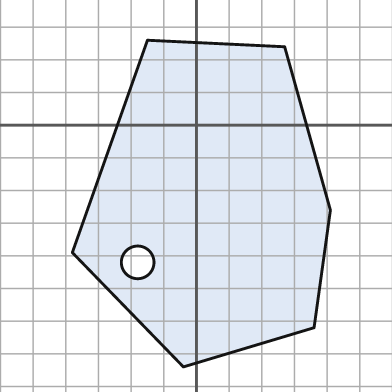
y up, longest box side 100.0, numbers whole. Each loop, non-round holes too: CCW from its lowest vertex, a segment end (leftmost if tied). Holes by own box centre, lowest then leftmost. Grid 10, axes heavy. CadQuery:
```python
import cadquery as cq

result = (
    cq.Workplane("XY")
    .moveTo(-4.0, -74.0)
    .lineTo(36.0, -62.0)
    .lineTo(41.0, -26.0)
    .lineTo(27.0, 24.0)
    .lineTo(-15.0, 26.0)
    .lineTo(-38.0, -39.0)
    .close()
    .moveTo(-18.0, -42.0)
    .circle(5.0)
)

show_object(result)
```